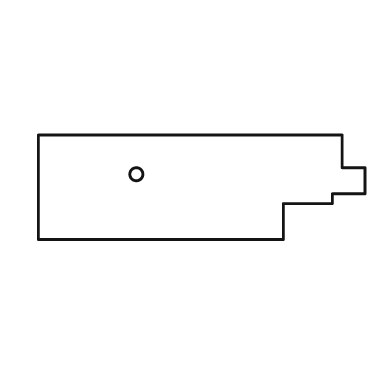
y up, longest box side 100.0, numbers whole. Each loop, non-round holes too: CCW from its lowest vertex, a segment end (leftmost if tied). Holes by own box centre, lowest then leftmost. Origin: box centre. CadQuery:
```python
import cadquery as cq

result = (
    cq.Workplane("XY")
    .moveTo(-50.0, -16.0)
    .lineTo(25.0, -16.0)
    .lineTo(25.0, -5.0)
    .lineTo(40.0, -5.0)
    .lineTo(40.0, -2.0)
    .lineTo(50.0, -2.0)
    .lineTo(50.0, 6.0)
    .lineTo(43.0, 6.0)
    .lineTo(43.0, 16.0)
    .lineTo(-50.0, 16.0)
    .close()
    .moveTo(-20.0, 4.0)
    .circle(2.0)
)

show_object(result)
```